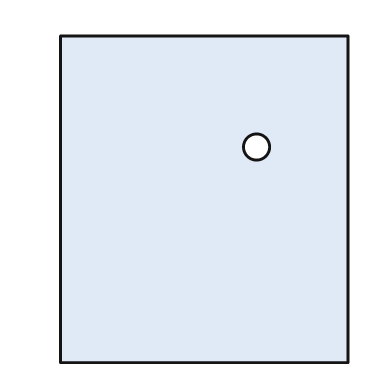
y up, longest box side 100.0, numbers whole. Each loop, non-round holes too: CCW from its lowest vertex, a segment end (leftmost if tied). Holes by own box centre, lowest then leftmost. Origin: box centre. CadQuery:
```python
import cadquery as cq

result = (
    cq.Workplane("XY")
    .moveTo(-44.0, -50.0)
    .lineTo(44.0, -50.0)
    .lineTo(44.0, 50.0)
    .lineTo(-44.0, 50.0)
    .close()
    .moveTo(16.0, 16.0)
    .circle(4.0)
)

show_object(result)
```